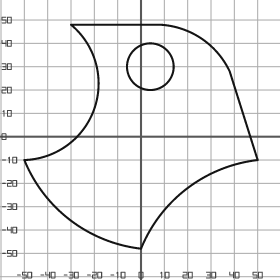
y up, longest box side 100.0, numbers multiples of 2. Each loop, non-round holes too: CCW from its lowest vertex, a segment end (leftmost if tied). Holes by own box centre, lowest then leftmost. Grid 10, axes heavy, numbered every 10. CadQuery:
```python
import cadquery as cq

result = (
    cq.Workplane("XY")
    .moveTo(0.0, -48.0)
    .threePointArc((20.0, -22.0), (50.0, -10.0))
    .lineTo(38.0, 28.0)
    .threePointArc((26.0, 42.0), (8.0, 48.0))
    .lineTo(-30.0, 48.0)
    .threePointArc((-20.0, 12.0), (-50.0, -10.0))
    .threePointArc((-30.0, -36.0), (0.0, -48.0))
    .close()
    .moveTo(4.0, 30.0)
    .circle(10.0)
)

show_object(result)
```